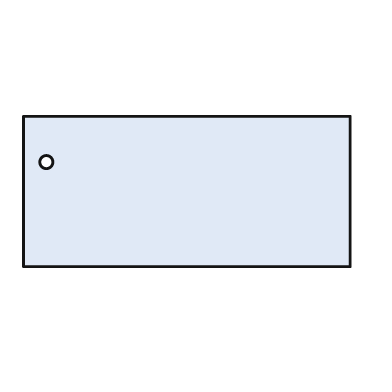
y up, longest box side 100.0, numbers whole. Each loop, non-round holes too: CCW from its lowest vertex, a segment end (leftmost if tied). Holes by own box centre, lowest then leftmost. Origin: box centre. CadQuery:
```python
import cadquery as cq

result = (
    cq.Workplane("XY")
    .moveTo(-50.0, -23.0)
    .lineTo(50.0, -23.0)
    .lineTo(50.0, 23.0)
    .lineTo(-50.0, 23.0)
    .close()
    .moveTo(-43.0, 9.0)
    .circle(2.0)
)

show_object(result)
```